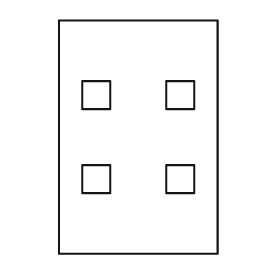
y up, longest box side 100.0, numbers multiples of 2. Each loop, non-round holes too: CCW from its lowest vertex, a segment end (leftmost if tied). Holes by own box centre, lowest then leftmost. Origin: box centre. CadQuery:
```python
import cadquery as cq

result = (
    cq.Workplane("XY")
    .moveTo(-34.0, -50.0)
    .lineTo(34.0, -50.0)
    .lineTo(34.0, 50.0)
    .lineTo(-34.0, 50.0)
    .close()
    .moveTo(-24.0, -24.0)
    .lineTo(-12.0, -24.0)
    .lineTo(-12.0, -12.0)
    .lineTo(-24.0, -12.0)
    .close()
    .moveTo(12.0, -24.0)
    .lineTo(24.0, -24.0)
    .lineTo(24.0, -12.0)
    .lineTo(12.0, -12.0)
    .close()
    .moveTo(-24.0, 12.0)
    .lineTo(-12.0, 12.0)
    .lineTo(-12.0, 24.0)
    .lineTo(-24.0, 24.0)
    .close()
    .moveTo(12.0, 12.0)
    .lineTo(24.0, 12.0)
    .lineTo(24.0, 24.0)
    .lineTo(12.0, 24.0)
    .close()
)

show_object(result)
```